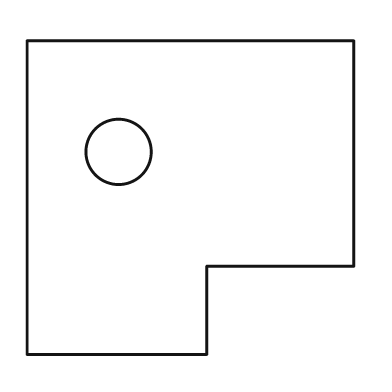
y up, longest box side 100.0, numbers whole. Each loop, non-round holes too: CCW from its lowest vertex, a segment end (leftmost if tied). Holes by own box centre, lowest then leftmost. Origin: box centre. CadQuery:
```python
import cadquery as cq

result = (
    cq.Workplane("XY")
    .moveTo(-50.0, -48.0)
    .lineTo(5.0, -48.0)
    .lineTo(5.0, -21.0)
    .lineTo(50.0, -21.0)
    .lineTo(50.0, 48.0)
    .lineTo(-50.0, 48.0)
    .close()
    .moveTo(-22.0, 14.0)
    .circle(10.0)
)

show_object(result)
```